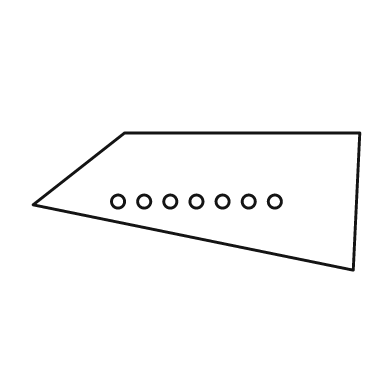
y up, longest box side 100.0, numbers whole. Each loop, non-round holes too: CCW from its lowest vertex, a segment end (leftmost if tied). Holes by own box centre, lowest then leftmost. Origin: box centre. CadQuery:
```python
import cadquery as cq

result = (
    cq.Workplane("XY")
    .moveTo(48.0, -21.0)
    .lineTo(50.0, 21.0)
    .lineTo(-22.0, 21.0)
    .lineTo(-50.0, -1.0)
    .close()
    .moveTo(-24.0, 0.0)
    .circle(2.0)
    .moveTo(-16.0, 0.0)
    .circle(2.0)
    .moveTo(-8.0, 0.0)
    .circle(2.0)
    .moveTo(0.0, 0.0)
    .circle(2.0)
    .moveTo(8.0, 0.0)
    .circle(2.0)
    .moveTo(16.0, 0.0)
    .circle(2.0)
    .moveTo(24.0, 0.0)
    .circle(2.0)
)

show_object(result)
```